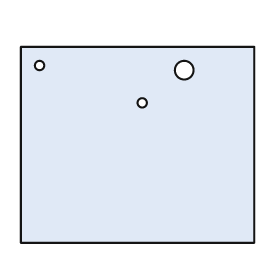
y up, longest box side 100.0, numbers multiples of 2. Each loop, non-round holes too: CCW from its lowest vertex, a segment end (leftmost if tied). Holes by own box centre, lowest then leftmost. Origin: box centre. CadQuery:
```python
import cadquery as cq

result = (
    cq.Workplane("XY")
    .moveTo(-50.0, -42.0)
    .lineTo(50.0, -42.0)
    .lineTo(50.0, 42.0)
    .lineTo(-50.0, 42.0)
    .close()
    .moveTo(2.0, 18.0)
    .circle(2.0)
    .moveTo(20.0, 32.0)
    .circle(4.0)
    .moveTo(-42.0, 34.0)
    .circle(2.0)
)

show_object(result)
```